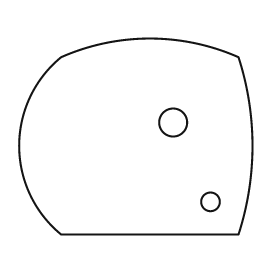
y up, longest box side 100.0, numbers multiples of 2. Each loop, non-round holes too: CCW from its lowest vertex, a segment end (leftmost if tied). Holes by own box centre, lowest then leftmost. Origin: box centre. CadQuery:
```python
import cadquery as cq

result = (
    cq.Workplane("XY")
    .moveTo(-32.0, -42.0)
    .lineTo(44.0, -42.0)
    .threePointArc((50.0, -4.0), (44.0, 34.0))
    .threePointArc((6.0, 42.0), (-32.0, 34.0))
    .threePointArc((-50.0, -4.0), (-32.0, -42.0))
    .close()
    .moveTo(32.0, -28.0)
    .circle(4.0)
    .moveTo(16.0, 6.0)
    .circle(6.0)
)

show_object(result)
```